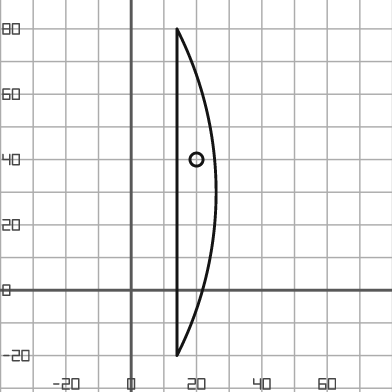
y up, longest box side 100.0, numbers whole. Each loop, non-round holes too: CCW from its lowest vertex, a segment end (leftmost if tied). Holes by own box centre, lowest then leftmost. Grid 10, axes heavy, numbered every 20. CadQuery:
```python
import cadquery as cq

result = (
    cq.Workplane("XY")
    .moveTo(14.0, -20.0)
    .threePointArc((26.0, 30.0), (14.0, 80.0))
    .close()
    .moveTo(20.0, 40.0)
    .circle(2.0)
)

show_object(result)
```